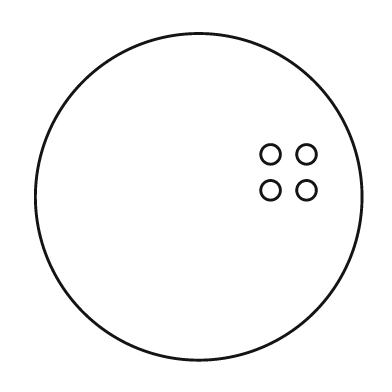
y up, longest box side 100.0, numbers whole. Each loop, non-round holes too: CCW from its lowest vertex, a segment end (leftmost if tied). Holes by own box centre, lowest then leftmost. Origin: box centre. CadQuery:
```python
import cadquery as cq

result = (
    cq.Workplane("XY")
    .moveTo(0.0, 0.0)
    .circle(50.0)
    .moveTo(22.0, 2.0)
    .circle(3.0)
    .moveTo(33.0, 2.0)
    .circle(3.0)
    .moveTo(22.0, 13.0)
    .circle(3.0)
    .moveTo(33.0, 13.0)
    .circle(3.0)
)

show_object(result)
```